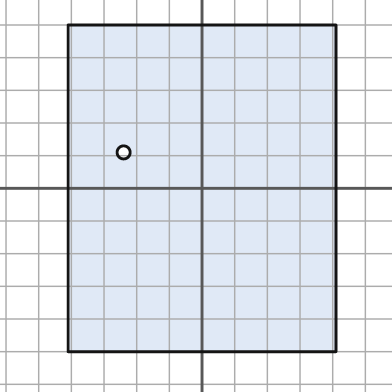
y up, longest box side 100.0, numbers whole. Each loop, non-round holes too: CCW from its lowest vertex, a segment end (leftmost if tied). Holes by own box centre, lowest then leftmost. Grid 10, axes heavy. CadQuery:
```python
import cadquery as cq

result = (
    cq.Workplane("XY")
    .moveTo(-41.0, -50.0)
    .lineTo(41.0, -50.0)
    .lineTo(41.0, 50.0)
    .lineTo(-41.0, 50.0)
    .close()
    .moveTo(-24.0, 11.0)
    .circle(2.0)
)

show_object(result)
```